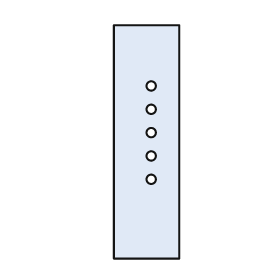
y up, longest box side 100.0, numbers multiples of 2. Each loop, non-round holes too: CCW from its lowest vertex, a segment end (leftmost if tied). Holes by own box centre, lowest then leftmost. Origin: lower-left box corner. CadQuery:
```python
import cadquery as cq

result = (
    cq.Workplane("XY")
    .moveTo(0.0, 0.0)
    .lineTo(28.0, 0.0)
    .lineTo(28.0, 100.0)
    .lineTo(0.0, 100.0)
    .close()
    .moveTo(16.0, 34.0)
    .circle(2.0)
    .moveTo(16.0, 44.0)
    .circle(2.0)
    .moveTo(16.0, 54.0)
    .circle(2.0)
    .moveTo(16.0, 64.0)
    .circle(2.0)
    .moveTo(16.0, 74.0)
    .circle(2.0)
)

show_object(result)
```